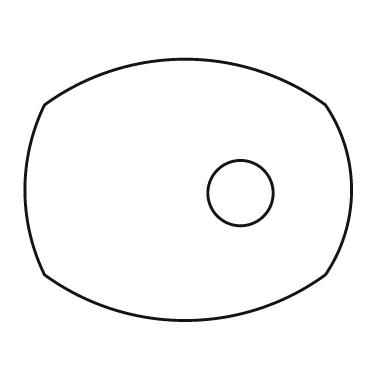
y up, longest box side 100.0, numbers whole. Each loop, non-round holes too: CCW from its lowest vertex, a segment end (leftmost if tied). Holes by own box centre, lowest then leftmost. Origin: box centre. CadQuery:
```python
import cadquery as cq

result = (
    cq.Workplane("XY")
    .moveTo(-44.0, -26.0)
    .threePointArc((-1.0, -40.0), (42.0, -26.0))
    .threePointArc((50.0, 0.0), (42.0, 26.0))
    .threePointArc((-1.0, 40.0), (-44.0, 26.0))
    .threePointArc((-50.0, 0.0), (-44.0, -26.0))
    .close()
    .moveTo(16.0, -1.0)
    .circle(10.0)
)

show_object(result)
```